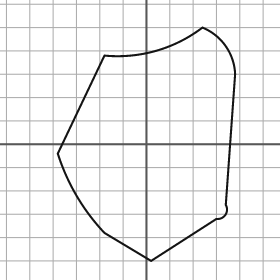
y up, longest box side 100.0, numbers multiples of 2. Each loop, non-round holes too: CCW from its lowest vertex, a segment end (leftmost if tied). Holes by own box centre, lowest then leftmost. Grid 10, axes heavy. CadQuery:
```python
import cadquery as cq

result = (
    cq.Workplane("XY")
    .moveTo(2.0, -50.0)
    .lineTo(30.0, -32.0)
    .threePointArc((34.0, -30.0), (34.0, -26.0))
    .lineTo(38.0, 30.0)
    .threePointArc((34.0, 42.0), (24.0, 50.0))
    .threePointArc((4.0, 40.0), (-18.0, 38.0))
    .lineTo(-38.0, -4.0)
    .threePointArc((-30.0, -22.0), (-18.0, -38.0))
    .close()
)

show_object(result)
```